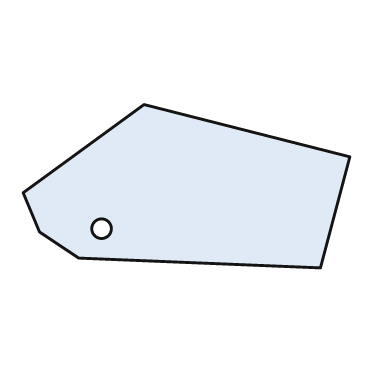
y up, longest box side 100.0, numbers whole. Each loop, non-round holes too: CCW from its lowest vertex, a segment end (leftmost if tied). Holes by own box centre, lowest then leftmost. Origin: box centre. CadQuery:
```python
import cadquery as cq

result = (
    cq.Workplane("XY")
    .moveTo(41.0, -25.0)
    .lineTo(50.0, 9.0)
    .lineTo(-13.0, 25.0)
    .lineTo(-50.0, -2.0)
    .lineTo(-45.0, -14.0)
    .lineTo(-33.0, -22.0)
    .close()
    .moveTo(-26.0, -13.0)
    .circle(3.0)
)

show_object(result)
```